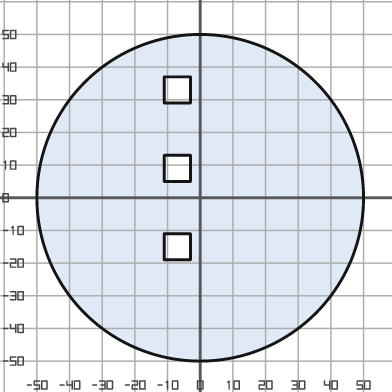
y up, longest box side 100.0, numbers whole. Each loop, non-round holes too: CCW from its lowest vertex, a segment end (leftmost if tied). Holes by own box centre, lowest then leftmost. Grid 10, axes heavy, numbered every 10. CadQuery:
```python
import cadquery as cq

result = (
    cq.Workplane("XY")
    .moveTo(0.0, 0.0)
    .circle(50.0)
    .moveTo(-11.0, -19.0)
    .lineTo(-3.0, -19.0)
    .lineTo(-3.0, -11.0)
    .lineTo(-11.0, -11.0)
    .close()
    .moveTo(-11.0, 5.0)
    .lineTo(-3.0, 5.0)
    .lineTo(-3.0, 13.0)
    .lineTo(-11.0, 13.0)
    .close()
    .moveTo(-11.0, 29.0)
    .lineTo(-3.0, 29.0)
    .lineTo(-3.0, 37.0)
    .lineTo(-11.0, 37.0)
    .close()
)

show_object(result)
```